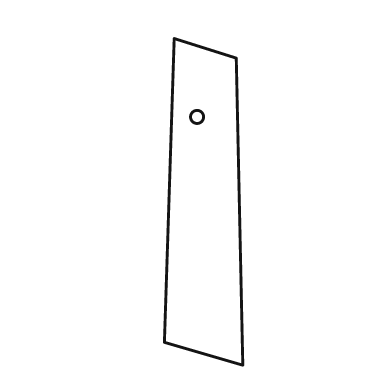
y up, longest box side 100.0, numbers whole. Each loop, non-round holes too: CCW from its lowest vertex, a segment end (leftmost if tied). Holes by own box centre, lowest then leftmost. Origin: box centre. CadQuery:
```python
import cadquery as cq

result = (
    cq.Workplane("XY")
    .moveTo(12.0, -50.0)
    .lineTo(10.0, 44.0)
    .lineTo(-9.0, 50.0)
    .lineTo(-12.0, -43.0)
    .close()
    .moveTo(-2.0, 26.0)
    .circle(2.0)
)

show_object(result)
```